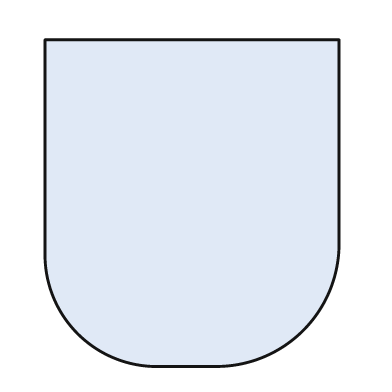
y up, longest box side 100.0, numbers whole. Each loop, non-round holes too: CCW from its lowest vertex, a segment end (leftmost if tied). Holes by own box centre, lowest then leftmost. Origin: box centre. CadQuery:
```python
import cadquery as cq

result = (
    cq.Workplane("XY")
    .moveTo(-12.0, -50.0)
    .lineTo(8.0, -50.0)
    .threePointArc((34.0, -39.0), (45.0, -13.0))
    .lineTo(45.0, 50.0)
    .lineTo(-45.0, 50.0)
    .lineTo(-45.0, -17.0)
    .threePointArc((-35.0, -40.0), (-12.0, -50.0))
    .close()
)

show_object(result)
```